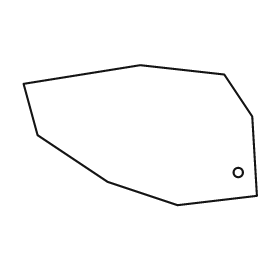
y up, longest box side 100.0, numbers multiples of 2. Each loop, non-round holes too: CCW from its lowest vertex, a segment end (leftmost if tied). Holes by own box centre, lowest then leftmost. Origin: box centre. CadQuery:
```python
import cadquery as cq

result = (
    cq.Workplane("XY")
    .moveTo(16.0, -30.0)
    .lineTo(50.0, -26.0)
    .lineTo(48.0, 8.0)
    .lineTo(36.0, 26.0)
    .lineTo(0.0, 30.0)
    .lineTo(-50.0, 22.0)
    .lineTo(-44.0, 0.0)
    .lineTo(-14.0, -20.0)
    .close()
    .moveTo(42.0, -16.0)
    .circle(2.0)
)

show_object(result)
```